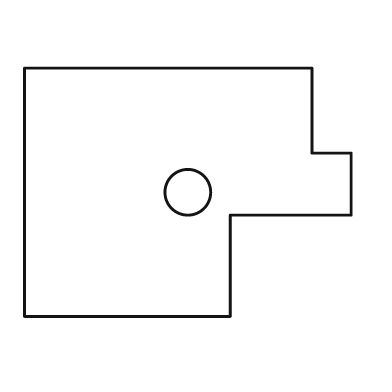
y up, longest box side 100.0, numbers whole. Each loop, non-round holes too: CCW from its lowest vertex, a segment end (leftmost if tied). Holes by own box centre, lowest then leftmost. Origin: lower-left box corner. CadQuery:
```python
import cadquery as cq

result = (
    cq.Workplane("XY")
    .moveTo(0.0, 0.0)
    .lineTo(63.0, 0.0)
    .lineTo(63.0, 31.0)
    .lineTo(100.0, 31.0)
    .lineTo(100.0, 50.0)
    .lineTo(88.0, 50.0)
    .lineTo(88.0, 76.0)
    .lineTo(0.0, 76.0)
    .close()
    .moveTo(50.0, 38.0)
    .circle(7.0)
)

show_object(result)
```